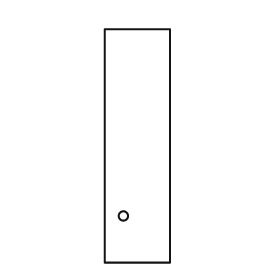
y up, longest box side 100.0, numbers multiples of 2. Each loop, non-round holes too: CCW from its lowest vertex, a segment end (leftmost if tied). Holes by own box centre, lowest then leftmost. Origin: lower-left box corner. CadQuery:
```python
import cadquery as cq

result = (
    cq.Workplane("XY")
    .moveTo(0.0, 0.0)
    .lineTo(28.0, 0.0)
    .lineTo(28.0, 100.0)
    .lineTo(0.0, 100.0)
    .close()
    .moveTo(8.0, 20.0)
    .circle(2.0)
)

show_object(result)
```